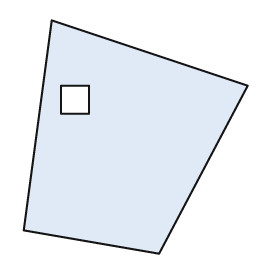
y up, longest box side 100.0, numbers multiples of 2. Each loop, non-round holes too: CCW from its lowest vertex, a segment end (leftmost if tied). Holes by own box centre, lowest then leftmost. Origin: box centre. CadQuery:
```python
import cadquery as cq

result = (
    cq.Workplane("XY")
    .moveTo(10.0, -50.0)
    .lineTo(48.0, 22.0)
    .lineTo(-36.0, 50.0)
    .lineTo(-48.0, -40.0)
    .close()
    .moveTo(-32.0, 10.0)
    .lineTo(-20.0, 10.0)
    .lineTo(-20.0, 22.0)
    .lineTo(-32.0, 22.0)
    .close()
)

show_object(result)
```